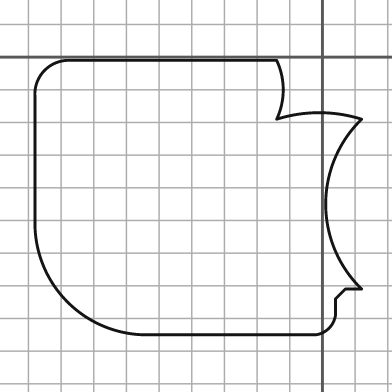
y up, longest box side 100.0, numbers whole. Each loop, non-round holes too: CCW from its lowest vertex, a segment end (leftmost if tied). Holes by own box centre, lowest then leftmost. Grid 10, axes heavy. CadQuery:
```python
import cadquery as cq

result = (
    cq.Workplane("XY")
    .moveTo(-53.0, -85.0)
    .lineTo(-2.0, -85.0)
    .threePointArc((2.0, -83.0), (4.0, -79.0))
    .lineTo(4.0, -74.0)
    .lineTo(7.0, -71.0)
    .lineTo(12.0, -71.0)
    .threePointArc((1.0, -45.0), (12.0, -19.0))
    .threePointArc((-1.0, -17.0), (-14.0, -19.0))
    .threePointArc((-12.0, -10.0), (-14.0, -1.0))
    .lineTo(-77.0, -1.0)
    .threePointArc((-85.0, -4.0), (-88.0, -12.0))
    .lineTo(-88.0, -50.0)
    .threePointArc((-78.0, -75.0), (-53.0, -85.0))
    .close()
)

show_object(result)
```